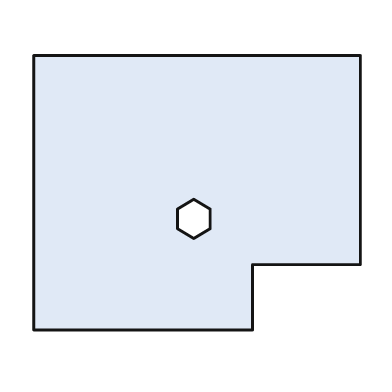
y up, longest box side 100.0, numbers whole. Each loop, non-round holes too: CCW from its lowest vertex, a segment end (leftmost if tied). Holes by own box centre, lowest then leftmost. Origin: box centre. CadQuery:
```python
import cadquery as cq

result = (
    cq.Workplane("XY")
    .moveTo(-50.0, -42.0)
    .lineTo(17.0, -42.0)
    .lineTo(17.0, -22.0)
    .lineTo(50.0, -22.0)
    .lineTo(50.0, 42.0)
    .lineTo(-50.0, 42.0)
    .close()
    .moveTo(-1.0, -14.0)
    .lineTo(4.0, -11.0)
    .lineTo(4.0, -5.0)
    .lineTo(-1.0, -2.0)
    .lineTo(-6.0, -5.0)
    .lineTo(-6.0, -11.0)
    .close()
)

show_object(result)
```